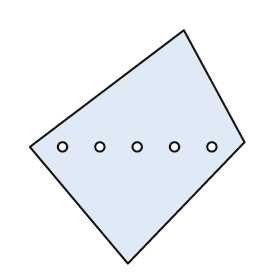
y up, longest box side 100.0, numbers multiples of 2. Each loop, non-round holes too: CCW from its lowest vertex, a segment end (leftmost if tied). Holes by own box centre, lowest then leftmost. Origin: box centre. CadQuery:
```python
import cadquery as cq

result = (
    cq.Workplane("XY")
    .moveTo(-4.0, -50.0)
    .lineTo(46.0, 2.0)
    .lineTo(20.0, 50.0)
    .lineTo(-46.0, 0.0)
    .close()
    .moveTo(-32.0, 0.0)
    .circle(2.0)
    .moveTo(-16.0, 0.0)
    .circle(2.0)
    .moveTo(0.0, 0.0)
    .circle(2.0)
    .moveTo(16.0, 0.0)
    .circle(2.0)
    .moveTo(32.0, 0.0)
    .circle(2.0)
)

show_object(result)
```